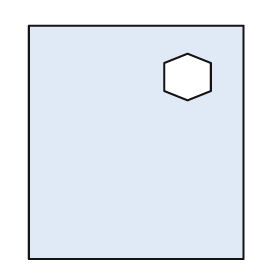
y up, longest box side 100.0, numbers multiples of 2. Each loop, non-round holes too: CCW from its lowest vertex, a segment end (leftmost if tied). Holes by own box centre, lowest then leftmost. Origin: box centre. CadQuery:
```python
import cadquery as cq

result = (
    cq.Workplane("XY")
    .moveTo(-46.0, -50.0)
    .lineTo(46.0, -50.0)
    .lineTo(46.0, 50.0)
    .lineTo(-46.0, 50.0)
    .close()
    .moveTo(22.0, 18.0)
    .lineTo(32.0, 22.0)
    .lineTo(32.0, 34.0)
    .lineTo(22.0, 38.0)
    .lineTo(12.0, 34.0)
    .lineTo(12.0, 22.0)
    .close()
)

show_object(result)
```